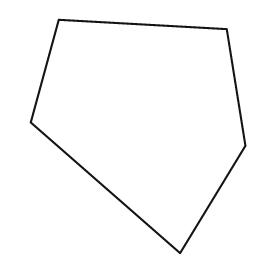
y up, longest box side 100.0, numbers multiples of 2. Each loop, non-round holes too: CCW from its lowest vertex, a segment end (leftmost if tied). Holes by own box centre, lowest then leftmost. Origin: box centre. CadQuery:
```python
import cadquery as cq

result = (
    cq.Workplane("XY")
    .moveTo(18.0, -50.0)
    .lineTo(46.0, -4.0)
    .lineTo(38.0, 46.0)
    .lineTo(-34.0, 50.0)
    .lineTo(-46.0, 6.0)
    .close()
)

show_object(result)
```